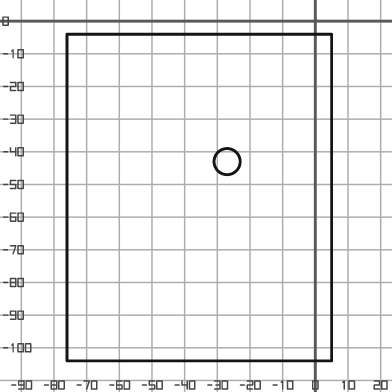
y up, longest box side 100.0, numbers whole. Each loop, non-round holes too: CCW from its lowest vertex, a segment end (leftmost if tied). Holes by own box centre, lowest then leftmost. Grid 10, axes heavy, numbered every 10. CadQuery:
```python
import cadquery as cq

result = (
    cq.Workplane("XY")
    .moveTo(-76.0, -104.0)
    .lineTo(5.0, -104.0)
    .lineTo(5.0, -4.0)
    .lineTo(-76.0, -4.0)
    .close()
    .moveTo(-27.0, -43.0)
    .circle(4.0)
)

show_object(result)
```